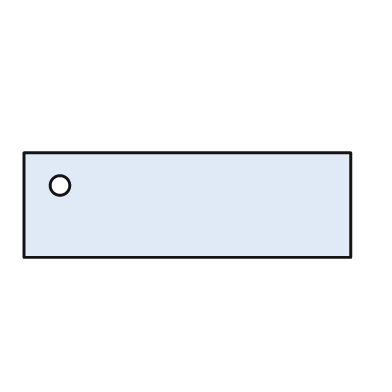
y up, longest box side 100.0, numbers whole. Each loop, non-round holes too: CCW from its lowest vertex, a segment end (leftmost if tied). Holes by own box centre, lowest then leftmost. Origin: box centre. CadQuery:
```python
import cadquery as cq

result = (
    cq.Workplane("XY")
    .moveTo(-50.0, -16.0)
    .lineTo(50.0, -16.0)
    .lineTo(50.0, 16.0)
    .lineTo(-50.0, 16.0)
    .close()
    .moveTo(-39.0, 6.0)
    .circle(3.0)
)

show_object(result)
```